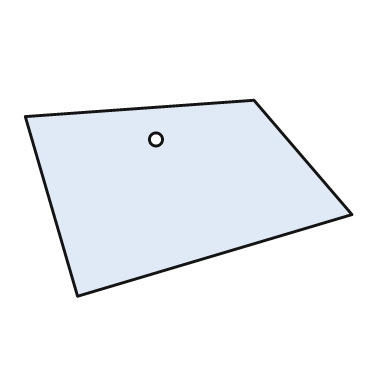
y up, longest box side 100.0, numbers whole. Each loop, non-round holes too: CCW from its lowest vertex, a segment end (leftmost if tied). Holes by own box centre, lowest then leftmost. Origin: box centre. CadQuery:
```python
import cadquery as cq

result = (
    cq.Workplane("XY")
    .moveTo(-34.0, -30.0)
    .lineTo(50.0, -5.0)
    .lineTo(20.0, 30.0)
    .lineTo(-50.0, 25.0)
    .close()
    .moveTo(-10.0, 18.0)
    .circle(2.0)
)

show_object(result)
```